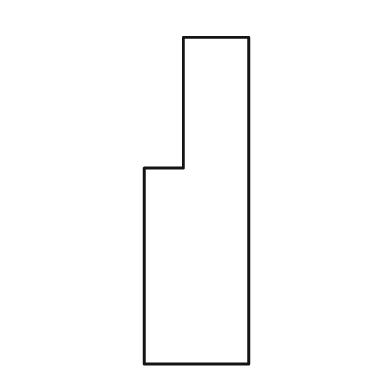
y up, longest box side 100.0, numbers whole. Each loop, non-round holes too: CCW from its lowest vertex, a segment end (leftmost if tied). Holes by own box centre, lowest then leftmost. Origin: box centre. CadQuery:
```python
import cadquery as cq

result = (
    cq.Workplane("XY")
    .moveTo(-16.0, -50.0)
    .lineTo(16.0, -50.0)
    .lineTo(16.0, 50.0)
    .lineTo(-4.0, 50.0)
    .lineTo(-4.0, 10.0)
    .lineTo(-16.0, 10.0)
    .close()
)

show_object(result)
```